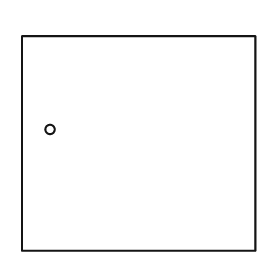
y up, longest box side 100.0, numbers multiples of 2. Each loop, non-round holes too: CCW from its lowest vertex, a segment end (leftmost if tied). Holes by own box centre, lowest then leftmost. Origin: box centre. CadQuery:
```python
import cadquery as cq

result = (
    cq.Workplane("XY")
    .moveTo(-50.0, -46.0)
    .lineTo(50.0, -46.0)
    .lineTo(50.0, 46.0)
    .lineTo(-50.0, 46.0)
    .close()
    .moveTo(-38.0, 6.0)
    .circle(2.0)
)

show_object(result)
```